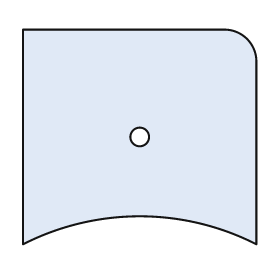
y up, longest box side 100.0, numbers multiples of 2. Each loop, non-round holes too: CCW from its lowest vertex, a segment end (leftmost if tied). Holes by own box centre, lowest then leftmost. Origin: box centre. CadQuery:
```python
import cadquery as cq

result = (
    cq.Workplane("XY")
    .moveTo(-50.0, -46.0)
    .threePointArc((0.0, -34.0), (50.0, -46.0))
    .lineTo(50.0, 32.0)
    .threePointArc((46.0, 42.0), (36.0, 46.0))
    .lineTo(-50.0, 46.0)
    .close()
    .moveTo(0.0, 0.0)
    .circle(4.0)
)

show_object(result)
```